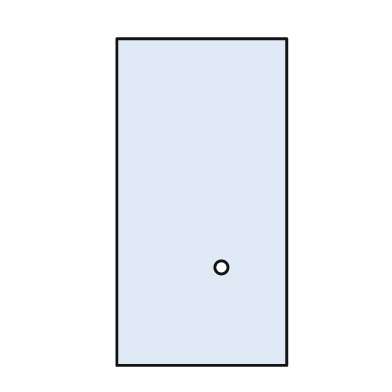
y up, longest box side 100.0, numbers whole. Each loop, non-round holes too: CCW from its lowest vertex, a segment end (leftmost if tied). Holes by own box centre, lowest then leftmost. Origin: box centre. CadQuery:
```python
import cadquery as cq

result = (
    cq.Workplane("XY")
    .moveTo(-26.0, -50.0)
    .lineTo(26.0, -50.0)
    .lineTo(26.0, 50.0)
    .lineTo(-26.0, 50.0)
    .close()
    .moveTo(6.0, -20.0)
    .circle(2.0)
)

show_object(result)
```